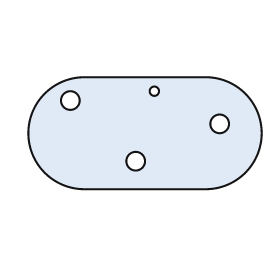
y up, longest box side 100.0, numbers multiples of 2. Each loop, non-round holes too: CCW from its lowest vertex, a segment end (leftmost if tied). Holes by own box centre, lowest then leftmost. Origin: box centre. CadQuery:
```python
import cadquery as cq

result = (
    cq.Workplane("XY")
    .moveTo(-26.0, -24.0)
    .lineTo(26.0, -24.0)
    .threePointArc((50.0, 0.0), (26.0, 24.0))
    .lineTo(-26.0, 24.0)
    .threePointArc((-50.0, 0.0), (-26.0, -24.0))
    .close()
    .moveTo(-4.0, -12.0)
    .circle(4.0)
    .moveTo(32.0, 4.0)
    .circle(4.0)
    .moveTo(-32.0, 14.0)
    .circle(4.0)
    .moveTo(4.0, 18.0)
    .circle(2.0)
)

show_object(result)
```